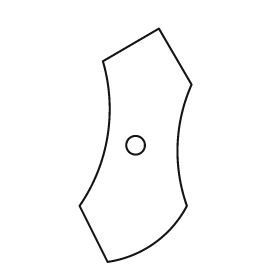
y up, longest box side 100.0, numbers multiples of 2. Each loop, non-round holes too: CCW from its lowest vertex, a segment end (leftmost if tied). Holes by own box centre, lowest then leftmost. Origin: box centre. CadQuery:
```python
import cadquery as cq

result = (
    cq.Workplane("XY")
    .moveTo(-12.0, -50.0)
    .threePointArc((8.0, -42.0), (22.0, -26.0))
    .threePointArc((18.0, 0.0), (24.0, 26.0))
    .lineTo(10.0, 50.0)
    .lineTo(-14.0, 36.0)
    .threePointArc((-12.0, 4.0), (-24.0, -26.0))
    .close()
    .moveTo(0.0, 0.0)
    .circle(4.0)
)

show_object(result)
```